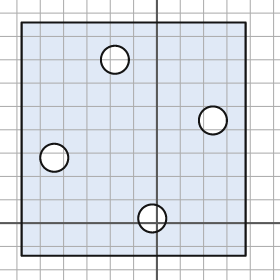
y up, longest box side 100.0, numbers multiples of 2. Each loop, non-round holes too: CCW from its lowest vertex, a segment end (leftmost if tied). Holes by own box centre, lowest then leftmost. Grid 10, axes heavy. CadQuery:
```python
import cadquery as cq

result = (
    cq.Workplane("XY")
    .moveTo(-58.0, -14.0)
    .lineTo(38.0, -14.0)
    .lineTo(38.0, 86.0)
    .lineTo(-58.0, 86.0)
    .close()
    .moveTo(-2.0, 2.0)
    .circle(6.0)
    .moveTo(-44.0, 28.0)
    .circle(6.0)
    .moveTo(24.0, 44.0)
    .circle(6.0)
    .moveTo(-18.0, 70.0)
    .circle(6.0)
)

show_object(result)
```